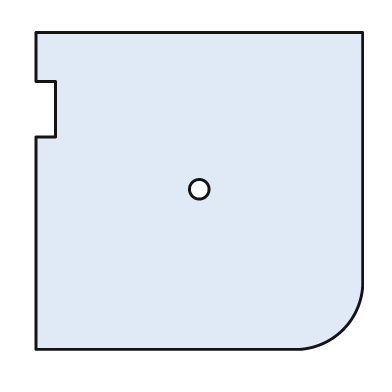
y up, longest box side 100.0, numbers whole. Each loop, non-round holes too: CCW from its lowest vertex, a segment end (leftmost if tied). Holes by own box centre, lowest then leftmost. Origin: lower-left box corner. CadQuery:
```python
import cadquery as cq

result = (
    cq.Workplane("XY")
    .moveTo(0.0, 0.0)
    .lineTo(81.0, 0.0)
    .threePointArc((94.0, 6.0), (100.0, 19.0))
    .lineTo(100.0, 97.0)
    .lineTo(0.0, 97.0)
    .lineTo(0.0, 82.0)
    .lineTo(6.0, 82.0)
    .lineTo(6.0, 65.0)
    .lineTo(0.0, 65.0)
    .close()
    .moveTo(50.0, 49.0)
    .circle(3.0)
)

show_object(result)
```